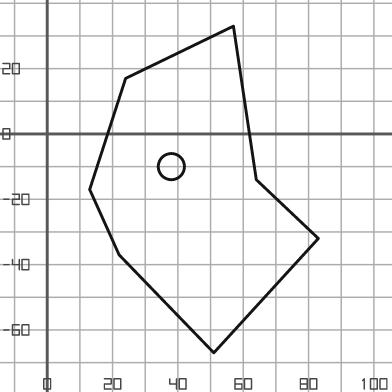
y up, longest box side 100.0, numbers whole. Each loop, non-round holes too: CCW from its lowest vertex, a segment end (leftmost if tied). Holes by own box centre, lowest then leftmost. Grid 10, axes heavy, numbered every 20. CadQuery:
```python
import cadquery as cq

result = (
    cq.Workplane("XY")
    .moveTo(51.0, -67.0)
    .lineTo(83.0, -32.0)
    .lineTo(64.0, -14.0)
    .lineTo(57.0, 33.0)
    .lineTo(24.0, 17.0)
    .lineTo(13.0, -17.0)
    .lineTo(22.0, -37.0)
    .close()
    .moveTo(38.0, -10.0)
    .circle(4.0)
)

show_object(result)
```